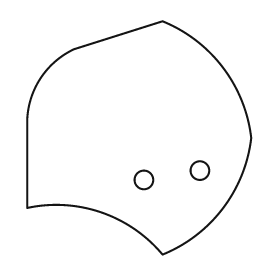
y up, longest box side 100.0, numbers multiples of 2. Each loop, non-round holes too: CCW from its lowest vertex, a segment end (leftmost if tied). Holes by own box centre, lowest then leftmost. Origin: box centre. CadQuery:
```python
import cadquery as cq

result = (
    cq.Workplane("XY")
    .moveTo(10.0, -50.0)
    .threePointArc((36.0, -30.0), (48.0, 0.0))
    .threePointArc((36.0, 30.0), (10.0, 50.0))
    .lineTo(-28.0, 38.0)
    .threePointArc((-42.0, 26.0), (-48.0, 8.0))
    .lineTo(-48.0, -30.0)
    .threePointArc((-16.0, -32.0), (10.0, -50.0))
    .close()
    .moveTo(2.0, -18.0)
    .circle(4.0)
    .moveTo(26.0, -14.0)
    .circle(4.0)
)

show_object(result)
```